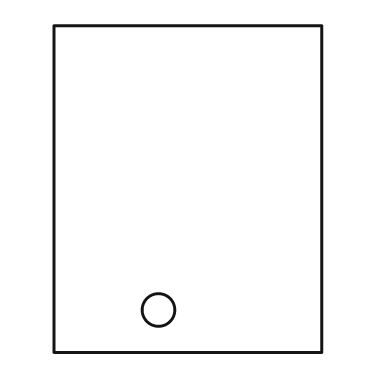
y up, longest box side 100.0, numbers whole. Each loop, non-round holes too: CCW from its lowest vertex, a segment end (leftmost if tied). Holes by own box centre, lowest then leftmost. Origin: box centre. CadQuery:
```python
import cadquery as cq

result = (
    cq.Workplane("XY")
    .moveTo(-41.0, -50.0)
    .lineTo(41.0, -50.0)
    .lineTo(41.0, 50.0)
    .lineTo(-41.0, 50.0)
    .close()
    .moveTo(-9.0, -37.0)
    .circle(5.0)
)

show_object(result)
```